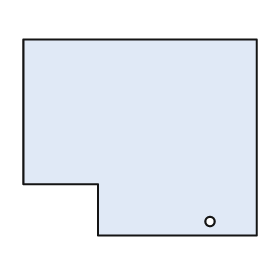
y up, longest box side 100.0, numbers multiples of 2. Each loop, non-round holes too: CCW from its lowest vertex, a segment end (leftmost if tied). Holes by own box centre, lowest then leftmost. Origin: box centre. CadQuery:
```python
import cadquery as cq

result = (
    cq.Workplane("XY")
    .moveTo(-18.0, -42.0)
    .lineTo(50.0, -42.0)
    .lineTo(50.0, 42.0)
    .lineTo(-50.0, 42.0)
    .lineTo(-50.0, -20.0)
    .lineTo(-18.0, -20.0)
    .close()
    .moveTo(30.0, -36.0)
    .circle(2.0)
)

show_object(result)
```